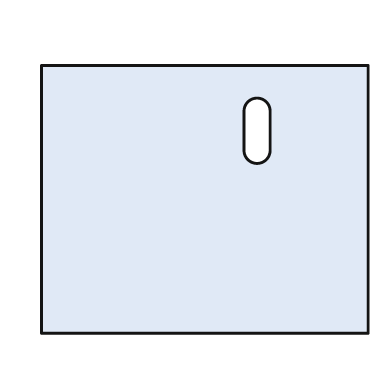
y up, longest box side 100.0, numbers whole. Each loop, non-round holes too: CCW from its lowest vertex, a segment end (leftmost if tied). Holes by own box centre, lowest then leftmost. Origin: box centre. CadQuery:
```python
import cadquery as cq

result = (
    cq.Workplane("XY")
    .moveTo(-50.0, -41.0)
    .lineTo(50.0, -41.0)
    .lineTo(50.0, 41.0)
    .lineTo(-50.0, 41.0)
    .close()
    .moveTo(12.0, 15.0)
    .threePointArc((16.0, 11.0), (20.0, 15.0))
    .lineTo(20.0, 27.0)
    .threePointArc((16.0, 31.0), (12.0, 27.0))
    .close()
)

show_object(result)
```